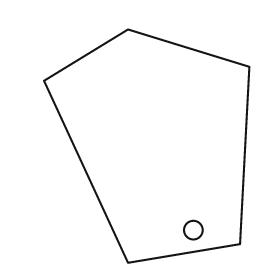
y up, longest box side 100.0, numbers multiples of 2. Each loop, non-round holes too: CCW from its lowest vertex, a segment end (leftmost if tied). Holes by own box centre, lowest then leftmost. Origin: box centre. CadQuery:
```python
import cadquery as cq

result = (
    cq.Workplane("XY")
    .moveTo(-8.0, -50.0)
    .lineTo(40.0, -42.0)
    .lineTo(44.0, 34.0)
    .lineTo(-8.0, 50.0)
    .lineTo(-44.0, 28.0)
    .close()
    .moveTo(20.0, -36.0)
    .circle(4.0)
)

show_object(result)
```